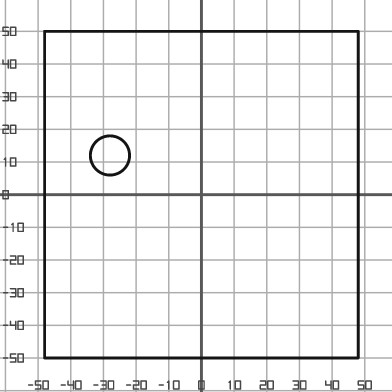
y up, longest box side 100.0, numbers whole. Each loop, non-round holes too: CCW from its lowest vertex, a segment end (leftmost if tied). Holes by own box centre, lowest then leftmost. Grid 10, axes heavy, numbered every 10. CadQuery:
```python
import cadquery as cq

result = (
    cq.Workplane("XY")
    .moveTo(-48.0, -50.0)
    .lineTo(48.0, -50.0)
    .lineTo(48.0, 50.0)
    .lineTo(-48.0, 50.0)
    .close()
    .moveTo(-28.0, 12.0)
    .circle(6.0)
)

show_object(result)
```